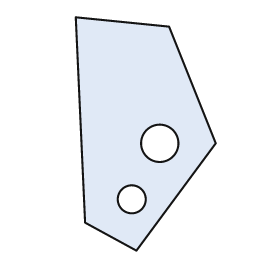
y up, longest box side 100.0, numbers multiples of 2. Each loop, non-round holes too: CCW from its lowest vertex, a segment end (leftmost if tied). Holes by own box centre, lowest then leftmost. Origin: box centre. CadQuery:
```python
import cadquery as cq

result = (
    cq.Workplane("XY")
    .moveTo(-4.0, -50.0)
    .lineTo(30.0, -4.0)
    .lineTo(10.0, 46.0)
    .lineTo(-30.0, 50.0)
    .lineTo(-26.0, -38.0)
    .close()
    .moveTo(-6.0, -28.0)
    .circle(6.0)
    .moveTo(6.0, -4.0)
    .circle(8.0)
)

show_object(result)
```